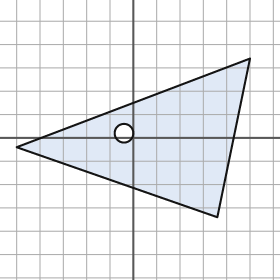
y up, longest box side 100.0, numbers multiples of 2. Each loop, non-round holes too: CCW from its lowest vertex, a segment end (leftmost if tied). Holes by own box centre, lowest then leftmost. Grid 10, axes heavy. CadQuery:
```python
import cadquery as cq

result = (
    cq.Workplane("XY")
    .moveTo(36.0, -34.0)
    .lineTo(50.0, 34.0)
    .lineTo(-50.0, -4.0)
    .close()
    .moveTo(-4.0, 2.0)
    .circle(4.0)
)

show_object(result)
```